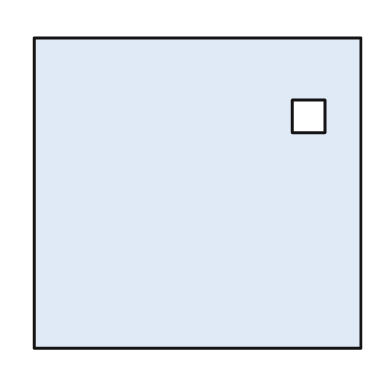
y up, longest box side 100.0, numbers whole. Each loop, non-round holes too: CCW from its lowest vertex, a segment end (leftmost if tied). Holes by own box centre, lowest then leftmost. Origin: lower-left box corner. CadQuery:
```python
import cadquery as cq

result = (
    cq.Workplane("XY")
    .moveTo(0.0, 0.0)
    .lineTo(100.0, 0.0)
    .lineTo(100.0, 95.0)
    .lineTo(0.0, 95.0)
    .close()
    .moveTo(79.0, 66.0)
    .lineTo(89.0, 66.0)
    .lineTo(89.0, 76.0)
    .lineTo(79.0, 76.0)
    .close()
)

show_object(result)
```